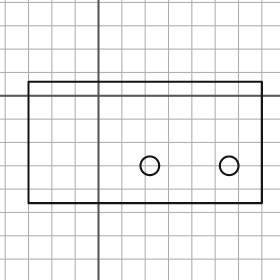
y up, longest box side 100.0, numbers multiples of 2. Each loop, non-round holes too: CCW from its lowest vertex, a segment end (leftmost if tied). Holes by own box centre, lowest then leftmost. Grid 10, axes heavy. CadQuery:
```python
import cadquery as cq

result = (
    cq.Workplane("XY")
    .moveTo(-30.0, -46.0)
    .lineTo(70.0, -46.0)
    .lineTo(70.0, 6.0)
    .lineTo(-30.0, 6.0)
    .close()
    .moveTo(22.0, -30.0)
    .circle(4.0)
    .moveTo(56.0, -30.0)
    .circle(4.0)
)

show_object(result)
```